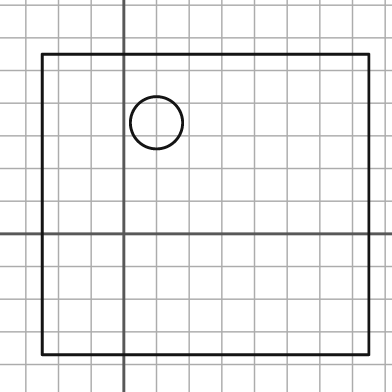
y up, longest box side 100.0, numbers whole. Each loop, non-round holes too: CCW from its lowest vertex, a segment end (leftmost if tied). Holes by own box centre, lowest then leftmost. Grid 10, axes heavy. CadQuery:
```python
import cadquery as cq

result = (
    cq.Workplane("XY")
    .moveTo(-25.0, -37.0)
    .lineTo(75.0, -37.0)
    .lineTo(75.0, 55.0)
    .lineTo(-25.0, 55.0)
    .close()
    .moveTo(10.0, 34.0)
    .circle(8.0)
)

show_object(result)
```